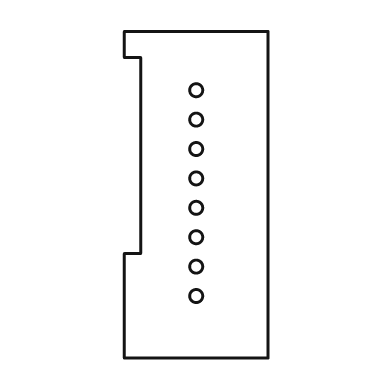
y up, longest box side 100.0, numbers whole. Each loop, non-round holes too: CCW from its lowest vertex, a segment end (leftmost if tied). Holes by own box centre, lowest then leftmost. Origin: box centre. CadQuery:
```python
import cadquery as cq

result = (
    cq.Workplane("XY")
    .moveTo(-22.0, -50.0)
    .lineTo(22.0, -50.0)
    .lineTo(22.0, 50.0)
    .lineTo(-22.0, 50.0)
    .lineTo(-22.0, 42.0)
    .lineTo(-17.0, 42.0)
    .lineTo(-17.0, -18.0)
    .lineTo(-22.0, -18.0)
    .close()
    .moveTo(0.0, -31.0)
    .circle(2.0)
    .moveTo(0.0, -22.0)
    .circle(2.0)
    .moveTo(0.0, -13.0)
    .circle(2.0)
    .moveTo(0.0, -4.0)
    .circle(2.0)
    .moveTo(0.0, 5.0)
    .circle(2.0)
    .moveTo(0.0, 14.0)
    .circle(2.0)
    .moveTo(0.0, 23.0)
    .circle(2.0)
    .moveTo(0.0, 32.0)
    .circle(2.0)
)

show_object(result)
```